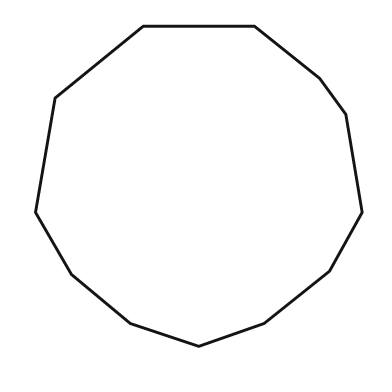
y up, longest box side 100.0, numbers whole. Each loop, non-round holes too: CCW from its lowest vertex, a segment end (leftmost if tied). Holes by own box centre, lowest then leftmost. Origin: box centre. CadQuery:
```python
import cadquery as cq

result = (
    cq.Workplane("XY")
    .moveTo(0.0, -49.0)
    .lineTo(20.0, -42.0)
    .lineTo(40.0, -26.0)
    .lineTo(50.0, -8.0)
    .lineTo(45.0, 22.0)
    .lineTo(37.0, 33.0)
    .lineTo(17.0, 49.0)
    .lineTo(-17.0, 49.0)
    .lineTo(-44.0, 27.0)
    .lineTo(-50.0, -8.0)
    .lineTo(-39.0, -27.0)
    .lineTo(-21.0, -42.0)
    .close()
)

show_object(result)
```